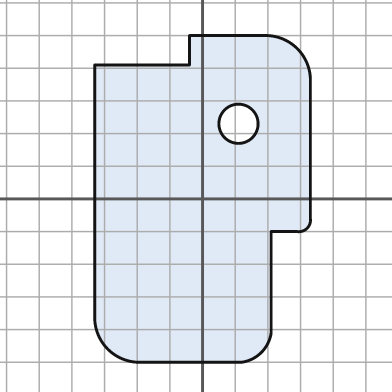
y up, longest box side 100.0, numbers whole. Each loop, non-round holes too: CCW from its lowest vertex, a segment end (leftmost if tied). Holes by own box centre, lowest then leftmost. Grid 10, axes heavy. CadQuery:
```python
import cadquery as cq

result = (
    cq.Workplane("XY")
    .moveTo(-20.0, -50.0)
    .lineTo(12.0, -50.0)
    .threePointArc((18.0, -47.0), (21.0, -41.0))
    .lineTo(21.0, -10.0)
    .lineTo(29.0, -10.0)
    .threePointArc((32.0, -9.0), (33.0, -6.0))
    .lineTo(33.0, 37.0)
    .threePointArc((29.0, 46.0), (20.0, 50.0))
    .lineTo(-4.0, 50.0)
    .lineTo(-4.0, 41.0)
    .lineTo(-33.0, 41.0)
    .lineTo(-33.0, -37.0)
    .threePointArc((-29.0, -46.0), (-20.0, -50.0))
    .close()
    .moveTo(11.0, 23.0)
    .circle(6.0)
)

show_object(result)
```